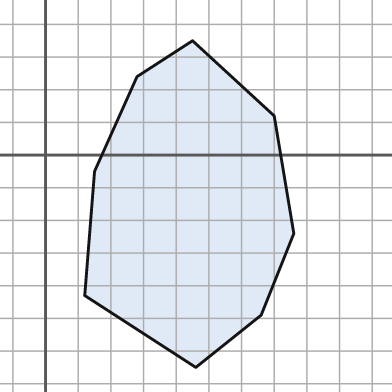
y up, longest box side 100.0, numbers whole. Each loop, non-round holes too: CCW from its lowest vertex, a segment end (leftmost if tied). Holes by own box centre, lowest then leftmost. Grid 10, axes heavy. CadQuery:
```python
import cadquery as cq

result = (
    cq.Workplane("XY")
    .moveTo(46.0, -65.0)
    .lineTo(66.0, -49.0)
    .lineTo(76.0, -24.0)
    .lineTo(70.0, 12.0)
    .lineTo(45.0, 35.0)
    .lineTo(28.0, 24.0)
    .lineTo(15.0, -5.0)
    .lineTo(12.0, -43.0)
    .close()
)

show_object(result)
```